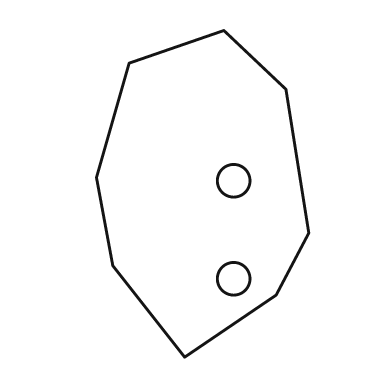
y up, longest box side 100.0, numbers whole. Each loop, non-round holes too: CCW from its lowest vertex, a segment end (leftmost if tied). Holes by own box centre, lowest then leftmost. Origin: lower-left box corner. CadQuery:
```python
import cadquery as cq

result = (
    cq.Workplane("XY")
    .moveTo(27.0, 0.0)
    .lineTo(55.0, 19.0)
    .lineTo(65.0, 38.0)
    .lineTo(58.0, 82.0)
    .lineTo(39.0, 100.0)
    .lineTo(10.0, 90.0)
    .lineTo(0.0, 55.0)
    .lineTo(5.0, 28.0)
    .close()
    .moveTo(42.0, 24.0)
    .circle(5.0)
    .moveTo(42.0, 54.0)
    .circle(5.0)
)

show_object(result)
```